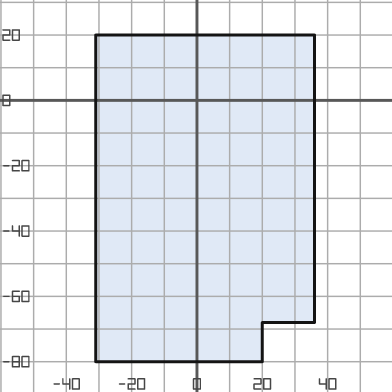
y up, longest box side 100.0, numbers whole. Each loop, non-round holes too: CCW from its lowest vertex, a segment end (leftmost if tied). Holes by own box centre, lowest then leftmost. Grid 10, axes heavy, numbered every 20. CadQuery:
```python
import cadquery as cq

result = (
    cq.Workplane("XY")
    .moveTo(-31.0, -80.0)
    .lineTo(20.0, -80.0)
    .lineTo(20.0, -68.0)
    .lineTo(36.0, -68.0)
    .lineTo(36.0, 20.0)
    .lineTo(-31.0, 20.0)
    .close()
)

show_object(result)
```